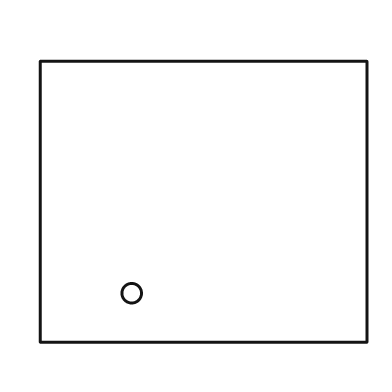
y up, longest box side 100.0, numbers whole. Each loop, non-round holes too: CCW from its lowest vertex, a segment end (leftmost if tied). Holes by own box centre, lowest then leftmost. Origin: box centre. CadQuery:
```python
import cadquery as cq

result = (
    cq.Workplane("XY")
    .moveTo(-50.0, -43.0)
    .lineTo(50.0, -43.0)
    .lineTo(50.0, 43.0)
    .lineTo(-50.0, 43.0)
    .close()
    .moveTo(-22.0, -28.0)
    .circle(3.0)
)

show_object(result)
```